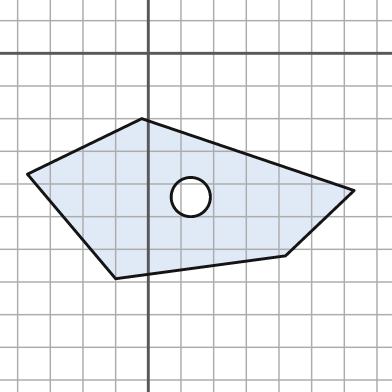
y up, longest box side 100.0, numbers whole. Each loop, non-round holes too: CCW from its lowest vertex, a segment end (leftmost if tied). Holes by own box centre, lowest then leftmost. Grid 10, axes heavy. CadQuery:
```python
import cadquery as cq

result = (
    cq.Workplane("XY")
    .moveTo(-10.0, -69.0)
    .lineTo(42.0, -62.0)
    .lineTo(63.0, -42.0)
    .lineTo(-2.0, -20.0)
    .lineTo(-37.0, -37.0)
    .close()
    .moveTo(13.0, -44.0)
    .circle(6.0)
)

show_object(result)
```